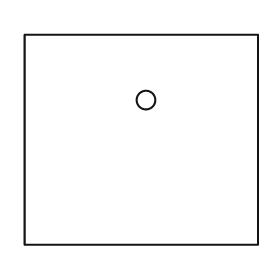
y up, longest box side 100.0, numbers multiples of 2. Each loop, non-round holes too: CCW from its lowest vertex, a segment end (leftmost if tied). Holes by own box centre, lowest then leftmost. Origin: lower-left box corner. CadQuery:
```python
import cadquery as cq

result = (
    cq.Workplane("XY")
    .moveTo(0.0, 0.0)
    .lineTo(100.0, 0.0)
    .lineTo(100.0, 90.0)
    .lineTo(0.0, 90.0)
    .close()
    .moveTo(52.0, 62.0)
    .circle(4.0)
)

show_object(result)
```